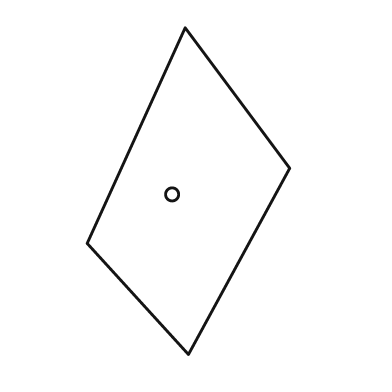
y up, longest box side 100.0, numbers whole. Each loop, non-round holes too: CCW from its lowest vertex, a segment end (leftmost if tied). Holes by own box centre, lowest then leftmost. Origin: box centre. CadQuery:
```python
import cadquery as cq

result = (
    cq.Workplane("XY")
    .moveTo(0.0, -50.0)
    .lineTo(31.0, 7.0)
    .lineTo(-1.0, 50.0)
    .lineTo(-31.0, -16.0)
    .close()
    .moveTo(-5.0, -1.0)
    .circle(2.0)
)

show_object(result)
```